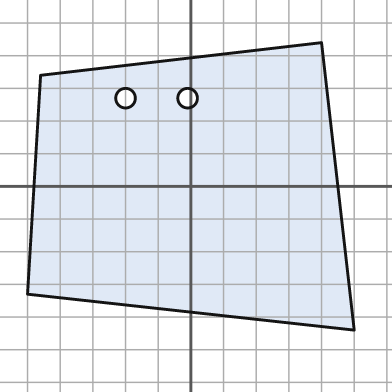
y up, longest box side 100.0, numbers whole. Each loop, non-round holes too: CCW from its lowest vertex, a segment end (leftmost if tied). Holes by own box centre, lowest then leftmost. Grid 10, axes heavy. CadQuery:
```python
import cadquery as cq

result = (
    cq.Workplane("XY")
    .moveTo(50.0, -44.0)
    .lineTo(40.0, 44.0)
    .lineTo(-46.0, 34.0)
    .lineTo(-50.0, -33.0)
    .close()
    .moveTo(-20.0, 27.0)
    .circle(3.0)
    .moveTo(-1.0, 27.0)
    .circle(3.0)
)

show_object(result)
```